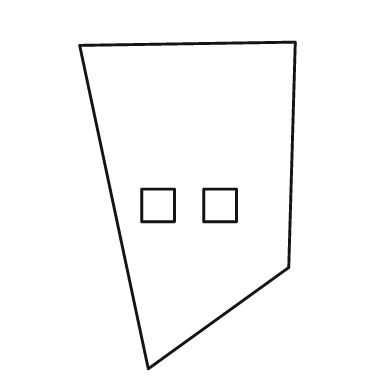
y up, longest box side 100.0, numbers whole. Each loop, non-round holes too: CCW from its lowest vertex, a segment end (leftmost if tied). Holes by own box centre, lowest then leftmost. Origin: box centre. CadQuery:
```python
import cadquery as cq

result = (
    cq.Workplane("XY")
    .moveTo(-12.0, -50.0)
    .lineTo(31.0, -19.0)
    .lineTo(33.0, 50.0)
    .lineTo(-33.0, 49.0)
    .close()
    .moveTo(-14.0, -5.0)
    .lineTo(-4.0, -5.0)
    .lineTo(-4.0, 5.0)
    .lineTo(-14.0, 5.0)
    .close()
    .moveTo(5.0, -5.0)
    .lineTo(15.0, -5.0)
    .lineTo(15.0, 5.0)
    .lineTo(5.0, 5.0)
    .close()
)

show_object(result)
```